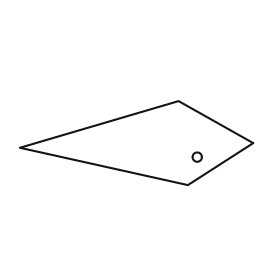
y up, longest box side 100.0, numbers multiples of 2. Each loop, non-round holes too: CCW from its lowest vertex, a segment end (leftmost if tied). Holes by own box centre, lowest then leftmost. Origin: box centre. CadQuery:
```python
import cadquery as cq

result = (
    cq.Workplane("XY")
    .moveTo(22.0, -18.0)
    .lineTo(50.0, 0.0)
    .lineTo(18.0, 18.0)
    .lineTo(-50.0, -2.0)
    .close()
    .moveTo(26.0, -6.0)
    .circle(2.0)
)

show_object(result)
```